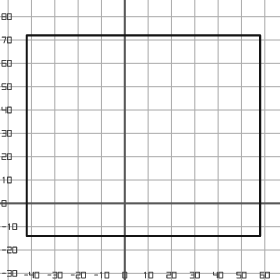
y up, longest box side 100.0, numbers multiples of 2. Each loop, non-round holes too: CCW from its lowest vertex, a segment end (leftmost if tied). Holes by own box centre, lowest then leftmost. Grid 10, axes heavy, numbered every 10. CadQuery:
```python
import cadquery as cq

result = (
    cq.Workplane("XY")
    .moveTo(-42.0, -14.0)
    .lineTo(58.0, -14.0)
    .lineTo(58.0, 72.0)
    .lineTo(-42.0, 72.0)
    .close()
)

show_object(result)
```